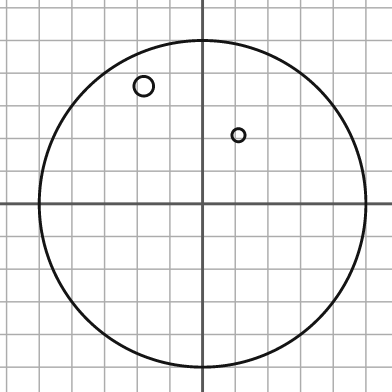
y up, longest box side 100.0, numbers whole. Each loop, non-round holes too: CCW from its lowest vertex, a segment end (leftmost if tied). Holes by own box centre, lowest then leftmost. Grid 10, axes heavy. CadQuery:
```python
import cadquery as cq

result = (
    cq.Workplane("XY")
    .moveTo(0.0, 0.0)
    .circle(50.0)
    .moveTo(11.0, 21.0)
    .circle(2.0)
    .moveTo(-18.0, 36.0)
    .circle(3.0)
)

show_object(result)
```